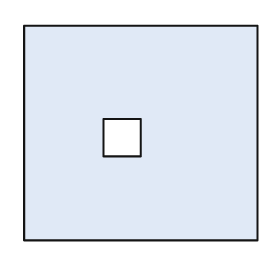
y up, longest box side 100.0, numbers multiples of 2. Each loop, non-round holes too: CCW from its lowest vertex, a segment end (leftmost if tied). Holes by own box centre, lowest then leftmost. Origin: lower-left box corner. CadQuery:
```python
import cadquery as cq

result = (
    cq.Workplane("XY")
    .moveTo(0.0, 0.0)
    .lineTo(100.0, 0.0)
    .lineTo(100.0, 92.0)
    .lineTo(0.0, 92.0)
    .close()
    .moveTo(34.0, 36.0)
    .lineTo(50.0, 36.0)
    .lineTo(50.0, 52.0)
    .lineTo(34.0, 52.0)
    .close()
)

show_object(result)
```